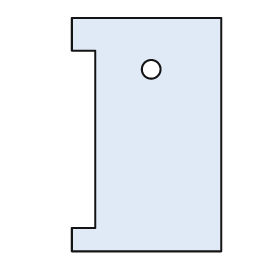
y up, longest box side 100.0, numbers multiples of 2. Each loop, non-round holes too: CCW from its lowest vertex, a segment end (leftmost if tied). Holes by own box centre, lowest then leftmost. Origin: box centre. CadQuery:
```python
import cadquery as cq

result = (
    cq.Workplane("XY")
    .moveTo(-32.0, -50.0)
    .lineTo(32.0, -50.0)
    .lineTo(32.0, 50.0)
    .lineTo(-32.0, 50.0)
    .lineTo(-32.0, 36.0)
    .lineTo(-22.0, 36.0)
    .lineTo(-22.0, -40.0)
    .lineTo(-32.0, -40.0)
    .close()
    .moveTo(2.0, 28.0)
    .circle(4.0)
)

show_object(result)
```